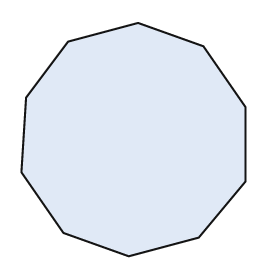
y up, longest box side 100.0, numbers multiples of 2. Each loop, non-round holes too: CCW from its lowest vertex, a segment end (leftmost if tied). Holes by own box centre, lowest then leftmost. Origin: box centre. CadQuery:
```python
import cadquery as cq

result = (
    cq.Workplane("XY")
    .moveTo(-2.0, -50.0)
    .lineTo(28.0, -42.0)
    .lineTo(48.0, -18.0)
    .lineTo(48.0, 14.0)
    .lineTo(30.0, 40.0)
    .lineTo(2.0, 50.0)
    .lineTo(-28.0, 42.0)
    .lineTo(-46.0, 18.0)
    .lineTo(-48.0, -14.0)
    .lineTo(-30.0, -40.0)
    .close()
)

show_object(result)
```